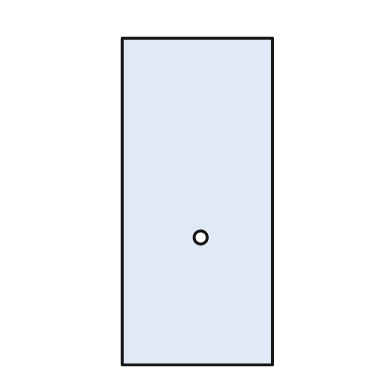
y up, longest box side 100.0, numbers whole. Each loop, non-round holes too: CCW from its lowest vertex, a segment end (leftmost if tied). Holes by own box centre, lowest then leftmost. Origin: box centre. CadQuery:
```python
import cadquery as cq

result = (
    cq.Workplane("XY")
    .moveTo(-23.0, -50.0)
    .lineTo(23.0, -50.0)
    .lineTo(23.0, 50.0)
    .lineTo(-23.0, 50.0)
    .close()
    .moveTo(1.0, -11.0)
    .circle(2.0)
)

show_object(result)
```